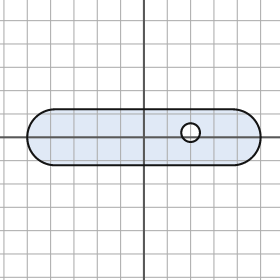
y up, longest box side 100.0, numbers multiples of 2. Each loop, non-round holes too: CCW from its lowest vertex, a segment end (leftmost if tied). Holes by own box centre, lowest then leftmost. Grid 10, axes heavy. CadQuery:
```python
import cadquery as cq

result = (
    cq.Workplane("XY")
    .moveTo(-38.0, -12.0)
    .lineTo(38.0, -12.0)
    .threePointArc((50.0, 0.0), (38.0, 12.0))
    .lineTo(-38.0, 12.0)
    .threePointArc((-50.0, 0.0), (-38.0, -12.0))
    .close()
    .moveTo(20.0, 2.0)
    .circle(4.0)
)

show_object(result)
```